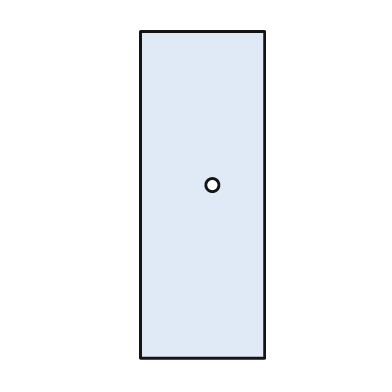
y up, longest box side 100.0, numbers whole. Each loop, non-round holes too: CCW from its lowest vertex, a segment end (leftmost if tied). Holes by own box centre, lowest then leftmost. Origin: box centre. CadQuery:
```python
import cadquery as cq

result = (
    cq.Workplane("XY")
    .moveTo(-19.0, -50.0)
    .lineTo(19.0, -50.0)
    .lineTo(19.0, 50.0)
    .lineTo(-19.0, 50.0)
    .close()
    .moveTo(3.0, 3.0)
    .circle(2.0)
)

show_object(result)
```